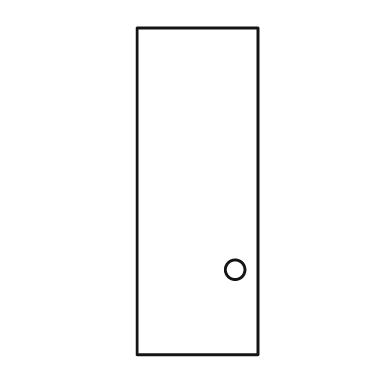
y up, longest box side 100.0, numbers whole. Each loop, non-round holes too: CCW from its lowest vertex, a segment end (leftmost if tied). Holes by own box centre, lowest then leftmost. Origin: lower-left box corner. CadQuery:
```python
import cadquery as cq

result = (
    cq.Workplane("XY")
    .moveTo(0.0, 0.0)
    .lineTo(37.0, 0.0)
    .lineTo(37.0, 100.0)
    .lineTo(0.0, 100.0)
    .close()
    .moveTo(30.0, 26.0)
    .circle(3.0)
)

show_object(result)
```